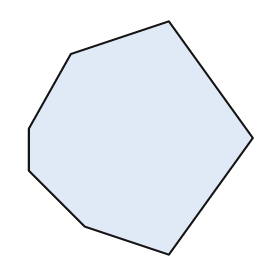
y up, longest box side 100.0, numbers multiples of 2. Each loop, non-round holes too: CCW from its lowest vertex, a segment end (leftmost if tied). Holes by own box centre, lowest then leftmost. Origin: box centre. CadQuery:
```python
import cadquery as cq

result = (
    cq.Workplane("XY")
    .moveTo(12.0, -50.0)
    .lineTo(48.0, 0.0)
    .lineTo(12.0, 50.0)
    .lineTo(-30.0, 36.0)
    .lineTo(-48.0, 4.0)
    .lineTo(-48.0, -14.0)
    .lineTo(-24.0, -38.0)
    .close()
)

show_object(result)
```